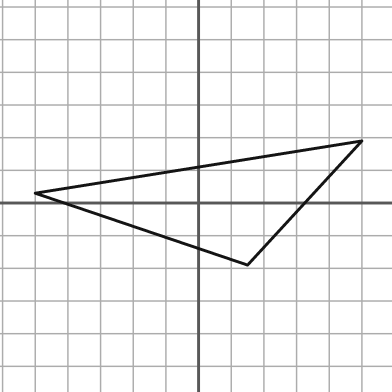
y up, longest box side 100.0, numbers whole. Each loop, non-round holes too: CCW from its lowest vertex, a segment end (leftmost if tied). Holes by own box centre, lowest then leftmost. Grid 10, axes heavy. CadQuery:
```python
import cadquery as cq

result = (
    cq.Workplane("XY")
    .moveTo(15.0, -19.0)
    .lineTo(50.0, 19.0)
    .lineTo(-50.0, 3.0)
    .close()
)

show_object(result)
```